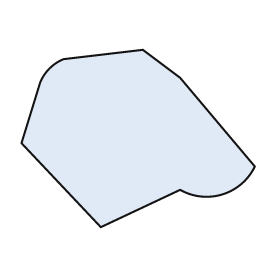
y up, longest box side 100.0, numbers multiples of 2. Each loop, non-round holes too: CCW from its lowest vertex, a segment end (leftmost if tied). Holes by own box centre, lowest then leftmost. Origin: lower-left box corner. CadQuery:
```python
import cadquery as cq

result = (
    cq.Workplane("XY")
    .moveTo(34.0, 0.0)
    .lineTo(68.0, 16.0)
    .threePointArc((86.0, 14.0), (100.0, 26.0))
    .lineTo(68.0, 64.0)
    .lineTo(52.0, 76.0)
    .lineTo(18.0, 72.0)
    .threePointArc((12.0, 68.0), (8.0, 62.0))
    .lineTo(0.0, 36.0)
    .close()
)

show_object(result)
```